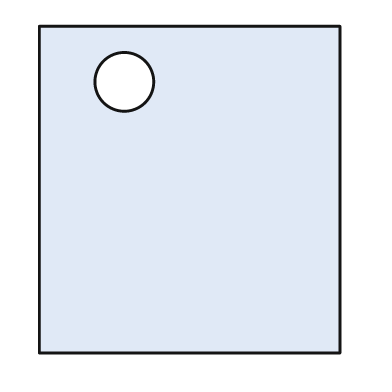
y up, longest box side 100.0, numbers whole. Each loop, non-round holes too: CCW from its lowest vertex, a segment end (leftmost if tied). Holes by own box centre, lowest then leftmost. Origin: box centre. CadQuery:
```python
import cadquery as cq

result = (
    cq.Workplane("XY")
    .moveTo(-46.0, -50.0)
    .lineTo(46.0, -50.0)
    .lineTo(46.0, 50.0)
    .lineTo(-46.0, 50.0)
    .close()
    .moveTo(-20.0, 33.0)
    .circle(9.0)
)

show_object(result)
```